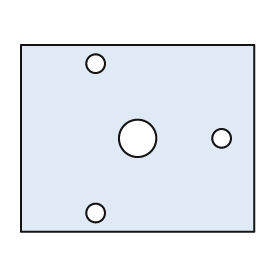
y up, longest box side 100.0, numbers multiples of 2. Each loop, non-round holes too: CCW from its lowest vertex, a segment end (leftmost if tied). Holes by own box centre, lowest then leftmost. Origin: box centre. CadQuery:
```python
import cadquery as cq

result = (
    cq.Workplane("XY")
    .moveTo(-50.0, -40.0)
    .lineTo(50.0, -40.0)
    .lineTo(50.0, 40.0)
    .lineTo(-50.0, 40.0)
    .close()
    .moveTo(-18.0, -32.0)
    .circle(4.0)
    .moveTo(0.0, 0.0)
    .circle(8.0)
    .moveTo(36.0, 0.0)
    .circle(4.0)
    .moveTo(-18.0, 32.0)
    .circle(4.0)
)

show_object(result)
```